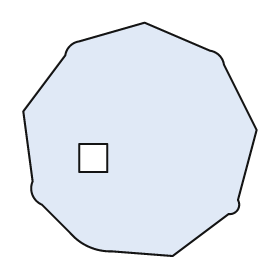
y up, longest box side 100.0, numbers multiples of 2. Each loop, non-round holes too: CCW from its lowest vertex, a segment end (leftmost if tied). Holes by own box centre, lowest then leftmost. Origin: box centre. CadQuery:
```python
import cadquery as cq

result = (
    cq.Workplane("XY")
    .moveTo(14.0, -50.0)
    .lineTo(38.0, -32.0)
    .threePointArc((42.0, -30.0), (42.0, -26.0))
    .lineTo(50.0, 4.0)
    .lineTo(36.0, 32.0)
    .threePointArc((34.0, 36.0), (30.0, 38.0))
    .lineTo(2.0, 50.0)
    .lineTo(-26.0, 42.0)
    .threePointArc((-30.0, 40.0), (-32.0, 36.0))
    .lineTo(-50.0, 12.0)
    .lineTo(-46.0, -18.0)
    .threePointArc((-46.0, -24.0), (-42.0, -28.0))
    .lineTo(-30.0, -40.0)
    .threePointArc((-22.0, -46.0), (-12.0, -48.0))
    .close()
    .moveTo(-26.0, -14.0)
    .lineTo(-14.0, -14.0)
    .lineTo(-14.0, -2.0)
    .lineTo(-26.0, -2.0)
    .close()
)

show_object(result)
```